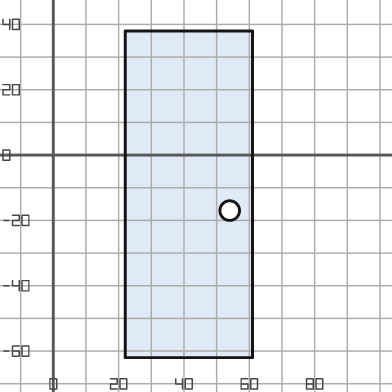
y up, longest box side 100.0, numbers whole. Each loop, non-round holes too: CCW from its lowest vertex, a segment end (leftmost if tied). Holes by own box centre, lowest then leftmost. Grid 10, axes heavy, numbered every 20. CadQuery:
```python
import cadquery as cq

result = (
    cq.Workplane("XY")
    .moveTo(22.0, -62.0)
    .lineTo(61.0, -62.0)
    .lineTo(61.0, 38.0)
    .lineTo(22.0, 38.0)
    .close()
    .moveTo(54.0, -17.0)
    .circle(3.0)
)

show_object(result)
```